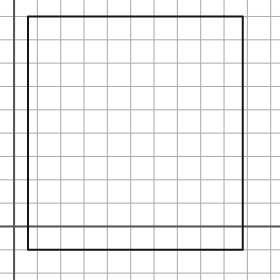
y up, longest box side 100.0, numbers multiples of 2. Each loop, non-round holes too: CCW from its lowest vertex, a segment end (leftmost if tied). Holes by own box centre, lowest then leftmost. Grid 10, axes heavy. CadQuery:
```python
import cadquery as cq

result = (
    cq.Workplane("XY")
    .moveTo(6.0, -10.0)
    .lineTo(98.0, -10.0)
    .lineTo(98.0, 90.0)
    .lineTo(6.0, 90.0)
    .close()
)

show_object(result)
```